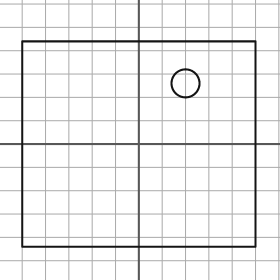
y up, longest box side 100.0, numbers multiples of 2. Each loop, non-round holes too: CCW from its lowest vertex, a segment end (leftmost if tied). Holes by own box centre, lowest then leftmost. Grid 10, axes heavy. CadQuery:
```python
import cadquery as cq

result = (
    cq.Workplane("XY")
    .moveTo(-50.0, -44.0)
    .lineTo(50.0, -44.0)
    .lineTo(50.0, 44.0)
    .lineTo(-50.0, 44.0)
    .close()
    .moveTo(20.0, 26.0)
    .circle(6.0)
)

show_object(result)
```